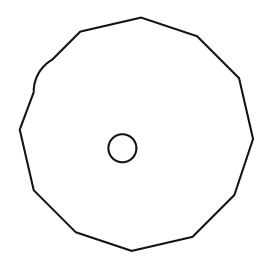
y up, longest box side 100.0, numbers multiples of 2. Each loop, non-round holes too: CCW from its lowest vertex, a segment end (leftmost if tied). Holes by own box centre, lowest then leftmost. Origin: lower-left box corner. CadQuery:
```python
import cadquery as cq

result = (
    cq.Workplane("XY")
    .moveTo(48.0, 0.0)
    .lineTo(74.0, 6.0)
    .lineTo(92.0, 24.0)
    .lineTo(100.0, 48.0)
    .lineTo(94.0, 74.0)
    .lineTo(76.0, 92.0)
    .lineTo(52.0, 100.0)
    .lineTo(26.0, 94.0)
    .lineTo(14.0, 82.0)
    .threePointArc((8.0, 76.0), (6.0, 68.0))
    .lineTo(0.0, 52.0)
    .lineTo(6.0, 26.0)
    .lineTo(24.0, 8.0)
    .close()
    .moveTo(44.0, 44.0)
    .circle(6.0)
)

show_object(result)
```